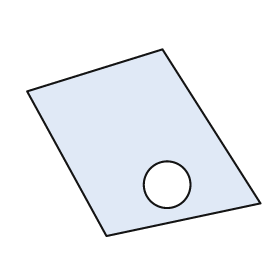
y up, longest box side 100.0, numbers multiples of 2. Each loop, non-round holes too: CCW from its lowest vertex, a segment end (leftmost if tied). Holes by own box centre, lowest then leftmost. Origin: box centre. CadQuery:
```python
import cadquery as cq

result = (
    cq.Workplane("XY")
    .moveTo(-16.0, -40.0)
    .lineTo(50.0, -26.0)
    .lineTo(8.0, 40.0)
    .lineTo(-50.0, 22.0)
    .close()
    .moveTo(10.0, -18.0)
    .circle(10.0)
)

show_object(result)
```